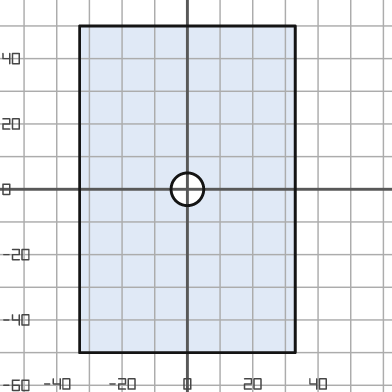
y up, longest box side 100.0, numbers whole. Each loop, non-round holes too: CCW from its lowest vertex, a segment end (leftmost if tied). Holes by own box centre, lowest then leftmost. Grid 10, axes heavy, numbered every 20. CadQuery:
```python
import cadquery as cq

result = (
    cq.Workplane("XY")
    .moveTo(-33.0, -50.0)
    .lineTo(33.0, -50.0)
    .lineTo(33.0, 50.0)
    .lineTo(-33.0, 50.0)
    .close()
    .moveTo(0.0, 0.0)
    .circle(5.0)
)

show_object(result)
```